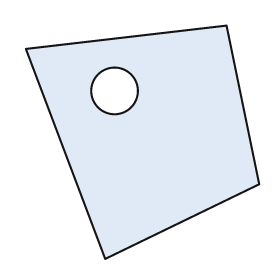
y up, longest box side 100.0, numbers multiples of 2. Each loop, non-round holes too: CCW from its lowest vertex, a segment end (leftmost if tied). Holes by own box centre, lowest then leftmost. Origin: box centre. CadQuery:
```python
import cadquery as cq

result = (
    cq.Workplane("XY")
    .moveTo(-16.0, -50.0)
    .lineTo(50.0, -18.0)
    .lineTo(36.0, 50.0)
    .lineTo(-50.0, 40.0)
    .close()
    .moveTo(-12.0, 22.0)
    .circle(10.0)
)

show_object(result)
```